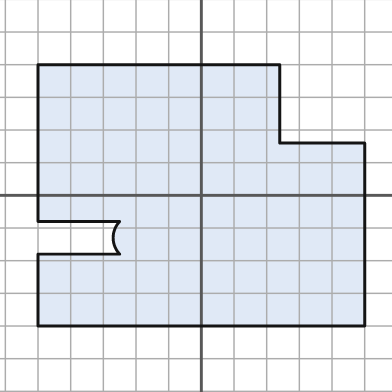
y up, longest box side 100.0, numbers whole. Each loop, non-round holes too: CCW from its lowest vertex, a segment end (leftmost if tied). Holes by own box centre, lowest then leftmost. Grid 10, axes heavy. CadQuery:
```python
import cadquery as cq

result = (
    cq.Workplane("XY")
    .moveTo(-50.0, -40.0)
    .lineTo(50.0, -40.0)
    .lineTo(50.0, 16.0)
    .lineTo(24.0, 16.0)
    .lineTo(24.0, 40.0)
    .lineTo(-50.0, 40.0)
    .lineTo(-50.0, -8.0)
    .lineTo(-25.0, -8.0)
    .threePointArc((-27.0, -13.0), (-25.0, -18.0))
    .lineTo(-50.0, -18.0)
    .close()
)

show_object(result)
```